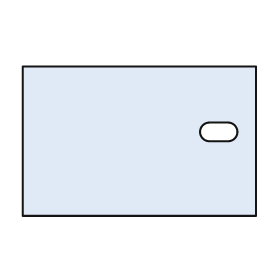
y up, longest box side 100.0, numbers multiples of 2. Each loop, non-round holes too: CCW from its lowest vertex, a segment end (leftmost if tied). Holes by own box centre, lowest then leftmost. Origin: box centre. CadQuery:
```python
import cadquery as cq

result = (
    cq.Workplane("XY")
    .moveTo(-50.0, -32.0)
    .lineTo(50.0, -32.0)
    .lineTo(50.0, 32.0)
    .lineTo(-50.0, 32.0)
    .close()
    .moveTo(30.0, 0.0)
    .lineTo(38.0, 0.0)
    .threePointArc((42.0, 4.0), (38.0, 8.0))
    .lineTo(30.0, 8.0)
    .threePointArc((26.0, 4.0), (30.0, 0.0))
    .close()
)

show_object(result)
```